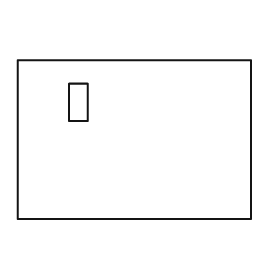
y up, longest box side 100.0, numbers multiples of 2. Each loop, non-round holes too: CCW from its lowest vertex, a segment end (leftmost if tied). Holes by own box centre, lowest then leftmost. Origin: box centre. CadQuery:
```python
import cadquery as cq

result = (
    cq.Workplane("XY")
    .moveTo(-50.0, -34.0)
    .lineTo(50.0, -34.0)
    .lineTo(50.0, 34.0)
    .lineTo(-50.0, 34.0)
    .close()
    .moveTo(-28.0, 8.0)
    .lineTo(-20.0, 8.0)
    .lineTo(-20.0, 24.0)
    .lineTo(-28.0, 24.0)
    .close()
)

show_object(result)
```